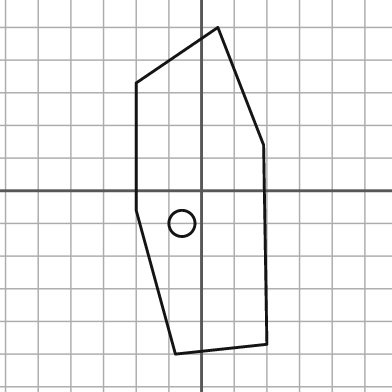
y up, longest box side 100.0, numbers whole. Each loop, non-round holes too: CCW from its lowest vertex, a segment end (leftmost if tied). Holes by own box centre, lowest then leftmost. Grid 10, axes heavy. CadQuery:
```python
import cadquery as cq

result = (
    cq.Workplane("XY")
    .moveTo(-8.0, -50.0)
    .lineTo(20.0, -47.0)
    .lineTo(19.0, 14.0)
    .lineTo(5.0, 50.0)
    .lineTo(-20.0, 33.0)
    .lineTo(-20.0, -6.0)
    .close()
    .moveTo(-6.0, -10.0)
    .circle(4.0)
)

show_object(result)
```